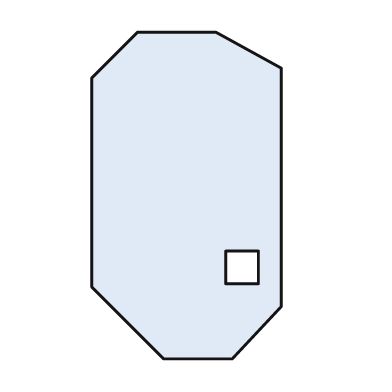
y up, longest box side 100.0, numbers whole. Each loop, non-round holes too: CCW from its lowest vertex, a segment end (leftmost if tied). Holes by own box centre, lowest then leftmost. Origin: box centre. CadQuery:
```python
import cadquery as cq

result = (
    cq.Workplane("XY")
    .moveTo(-7.0, -50.0)
    .lineTo(14.0, -50.0)
    .lineTo(29.0, -34.0)
    .lineTo(29.0, 39.0)
    .lineTo(9.0, 50.0)
    .lineTo(-15.0, 50.0)
    .lineTo(-29.0, 36.0)
    .lineTo(-29.0, -28.0)
    .close()
    .moveTo(12.0, -27.0)
    .lineTo(22.0, -27.0)
    .lineTo(22.0, -17.0)
    .lineTo(12.0, -17.0)
    .close()
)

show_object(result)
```